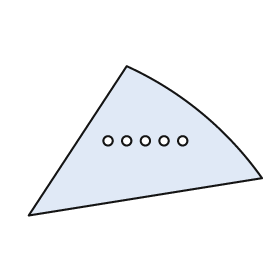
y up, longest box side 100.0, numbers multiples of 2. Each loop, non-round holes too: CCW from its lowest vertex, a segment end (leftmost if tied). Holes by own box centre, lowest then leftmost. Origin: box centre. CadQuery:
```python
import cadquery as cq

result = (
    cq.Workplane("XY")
    .moveTo(-50.0, -32.0)
    .lineTo(50.0, -16.0)
    .threePointArc((24.0, 12.0), (-8.0, 32.0))
    .close()
    .moveTo(-16.0, 0.0)
    .circle(2.0)
    .moveTo(-8.0, 0.0)
    .circle(2.0)
    .moveTo(0.0, 0.0)
    .circle(2.0)
    .moveTo(8.0, 0.0)
    .circle(2.0)
    .moveTo(16.0, 0.0)
    .circle(2.0)
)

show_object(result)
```